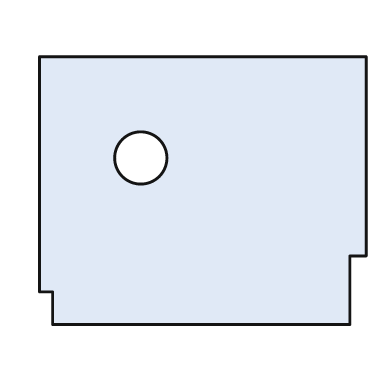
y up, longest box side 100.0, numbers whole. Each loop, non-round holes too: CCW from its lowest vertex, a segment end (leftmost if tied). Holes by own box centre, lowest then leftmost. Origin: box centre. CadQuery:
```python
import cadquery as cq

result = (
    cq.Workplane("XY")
    .moveTo(-46.0, -41.0)
    .lineTo(45.0, -41.0)
    .lineTo(45.0, -20.0)
    .lineTo(50.0, -20.0)
    .lineTo(50.0, 41.0)
    .lineTo(-50.0, 41.0)
    .lineTo(-50.0, -31.0)
    .lineTo(-46.0, -31.0)
    .close()
    .moveTo(-19.0, 10.0)
    .circle(8.0)
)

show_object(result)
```